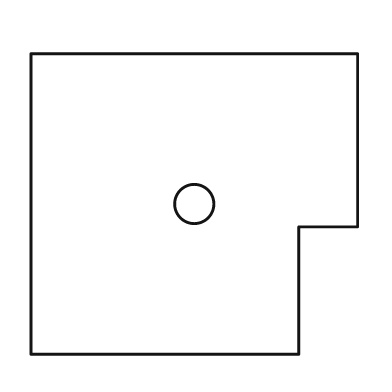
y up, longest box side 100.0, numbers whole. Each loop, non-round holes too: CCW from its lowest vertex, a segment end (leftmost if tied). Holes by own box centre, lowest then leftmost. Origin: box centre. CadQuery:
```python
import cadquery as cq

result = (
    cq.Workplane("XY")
    .moveTo(-50.0, -46.0)
    .lineTo(32.0, -46.0)
    .lineTo(32.0, -7.0)
    .lineTo(50.0, -7.0)
    .lineTo(50.0, 46.0)
    .lineTo(-50.0, 46.0)
    .close()
    .moveTo(0.0, 0.0)
    .circle(6.0)
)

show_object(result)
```